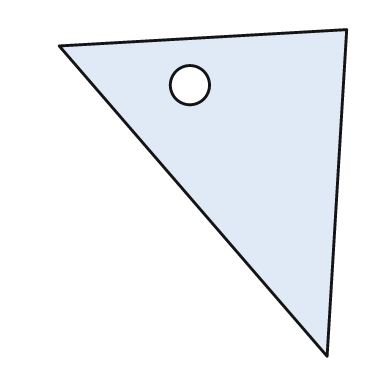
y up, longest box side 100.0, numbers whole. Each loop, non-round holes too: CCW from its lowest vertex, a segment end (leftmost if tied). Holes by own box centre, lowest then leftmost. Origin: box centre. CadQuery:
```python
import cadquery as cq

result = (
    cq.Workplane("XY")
    .moveTo(38.0, -50.0)
    .lineTo(44.0, 50.0)
    .lineTo(-44.0, 45.0)
    .close()
    .moveTo(-4.0, 33.0)
    .circle(6.0)
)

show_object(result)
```